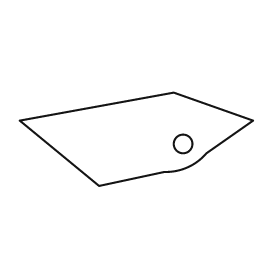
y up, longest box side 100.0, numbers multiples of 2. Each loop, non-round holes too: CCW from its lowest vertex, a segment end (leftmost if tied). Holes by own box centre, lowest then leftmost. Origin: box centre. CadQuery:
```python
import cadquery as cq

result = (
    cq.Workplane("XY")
    .moveTo(-16.0, -20.0)
    .lineTo(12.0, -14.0)
    .threePointArc((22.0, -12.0), (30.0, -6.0))
    .lineTo(50.0, 8.0)
    .lineTo(16.0, 20.0)
    .lineTo(-50.0, 8.0)
    .close()
    .moveTo(20.0, -2.0)
    .circle(4.0)
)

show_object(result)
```